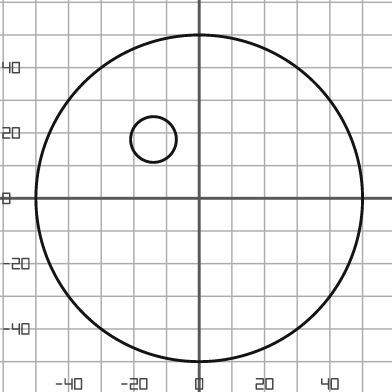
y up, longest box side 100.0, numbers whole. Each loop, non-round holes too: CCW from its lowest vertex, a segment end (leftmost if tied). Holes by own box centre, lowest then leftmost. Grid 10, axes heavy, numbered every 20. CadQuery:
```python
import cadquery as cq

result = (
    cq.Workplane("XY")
    .moveTo(0.0, 0.0)
    .circle(50.0)
    .moveTo(-14.0, 18.0)
    .circle(7.0)
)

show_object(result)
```